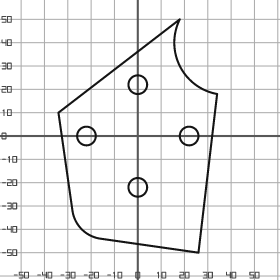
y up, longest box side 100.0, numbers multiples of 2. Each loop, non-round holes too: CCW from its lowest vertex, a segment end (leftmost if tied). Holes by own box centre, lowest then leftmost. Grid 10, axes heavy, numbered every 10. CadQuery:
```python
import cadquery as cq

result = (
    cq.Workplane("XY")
    .moveTo(26.0, -50.0)
    .lineTo(34.0, 18.0)
    .threePointArc((18.0, 30.0), (18.0, 50.0))
    .lineTo(-34.0, 10.0)
    .lineTo(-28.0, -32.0)
    .threePointArc((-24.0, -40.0), (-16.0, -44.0))
    .close()
    .moveTo(0.0, -22.0)
    .circle(4.0)
    .moveTo(-22.0, 0.0)
    .circle(4.0)
    .moveTo(22.0, 0.0)
    .circle(4.0)
    .moveTo(0.0, 22.0)
    .circle(4.0)
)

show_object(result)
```